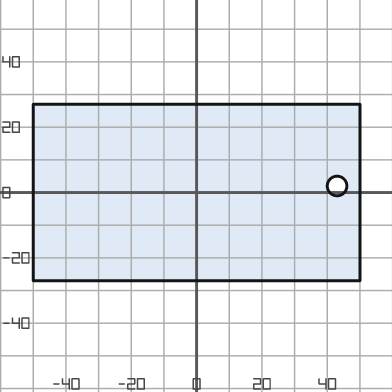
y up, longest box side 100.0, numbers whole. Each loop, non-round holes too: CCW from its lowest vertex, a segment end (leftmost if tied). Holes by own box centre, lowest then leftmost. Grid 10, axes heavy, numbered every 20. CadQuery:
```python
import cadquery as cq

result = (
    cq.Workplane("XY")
    .moveTo(-50.0, -27.0)
    .lineTo(50.0, -27.0)
    .lineTo(50.0, 27.0)
    .lineTo(-50.0, 27.0)
    .close()
    .moveTo(43.0, 2.0)
    .circle(3.0)
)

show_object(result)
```